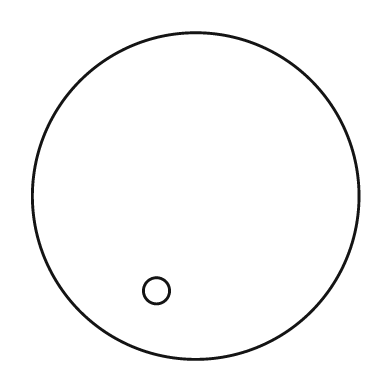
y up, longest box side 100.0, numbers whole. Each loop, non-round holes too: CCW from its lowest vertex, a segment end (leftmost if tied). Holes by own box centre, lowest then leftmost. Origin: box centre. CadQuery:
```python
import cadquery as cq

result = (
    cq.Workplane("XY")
    .moveTo(0.0, 0.0)
    .circle(50.0)
    .moveTo(-12.0, -29.0)
    .circle(4.0)
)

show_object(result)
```